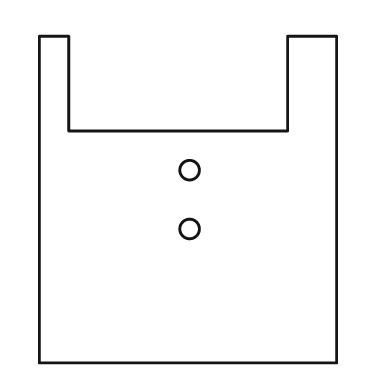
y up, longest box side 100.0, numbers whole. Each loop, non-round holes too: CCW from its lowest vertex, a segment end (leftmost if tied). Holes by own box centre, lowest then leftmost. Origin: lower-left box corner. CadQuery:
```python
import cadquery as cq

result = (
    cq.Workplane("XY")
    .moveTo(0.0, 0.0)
    .lineTo(91.0, 0.0)
    .lineTo(91.0, 100.0)
    .lineTo(76.0, 100.0)
    .lineTo(76.0, 71.0)
    .lineTo(9.0, 71.0)
    .lineTo(9.0, 100.0)
    .lineTo(0.0, 100.0)
    .close()
    .moveTo(46.0, 41.0)
    .circle(3.0)
    .moveTo(46.0, 59.0)
    .circle(3.0)
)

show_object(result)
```